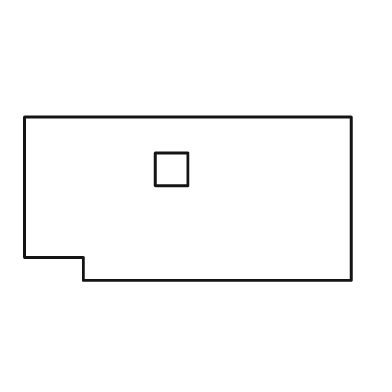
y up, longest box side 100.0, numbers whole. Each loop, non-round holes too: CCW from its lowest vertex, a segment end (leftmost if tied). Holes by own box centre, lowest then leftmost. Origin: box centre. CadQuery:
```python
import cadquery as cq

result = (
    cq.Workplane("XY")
    .moveTo(-32.0, -25.0)
    .lineTo(50.0, -25.0)
    .lineTo(50.0, 25.0)
    .lineTo(-50.0, 25.0)
    .lineTo(-50.0, -18.0)
    .lineTo(-32.0, -18.0)
    .close()
    .moveTo(-10.0, 4.0)
    .lineTo(0.0, 4.0)
    .lineTo(0.0, 14.0)
    .lineTo(-10.0, 14.0)
    .close()
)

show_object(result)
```